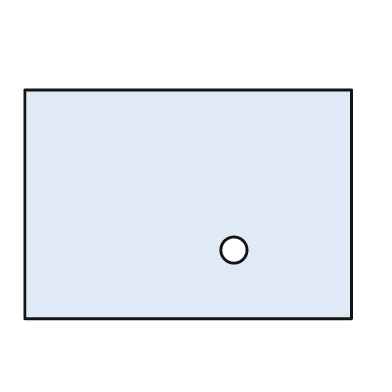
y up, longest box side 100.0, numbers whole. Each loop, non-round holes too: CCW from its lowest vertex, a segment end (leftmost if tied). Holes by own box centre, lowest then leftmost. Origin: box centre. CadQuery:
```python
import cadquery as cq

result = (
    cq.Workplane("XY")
    .moveTo(-50.0, -35.0)
    .lineTo(50.0, -35.0)
    .lineTo(50.0, 35.0)
    .lineTo(-50.0, 35.0)
    .close()
    .moveTo(14.0, -14.0)
    .circle(4.0)
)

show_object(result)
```